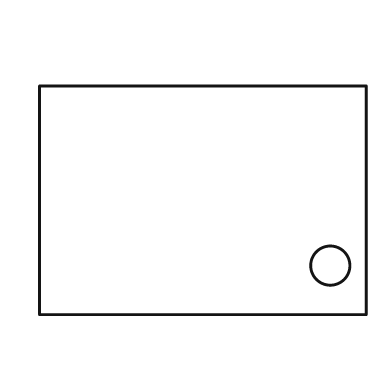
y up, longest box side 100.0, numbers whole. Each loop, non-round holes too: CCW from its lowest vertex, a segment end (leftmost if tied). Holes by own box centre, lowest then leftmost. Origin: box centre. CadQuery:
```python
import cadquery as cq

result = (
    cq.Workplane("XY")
    .moveTo(-50.0, -35.0)
    .lineTo(50.0, -35.0)
    .lineTo(50.0, 35.0)
    .lineTo(-50.0, 35.0)
    .close()
    .moveTo(39.0, -20.0)
    .circle(6.0)
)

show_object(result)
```